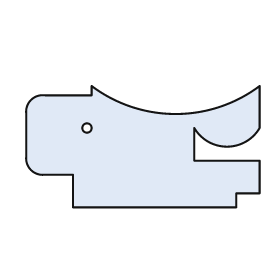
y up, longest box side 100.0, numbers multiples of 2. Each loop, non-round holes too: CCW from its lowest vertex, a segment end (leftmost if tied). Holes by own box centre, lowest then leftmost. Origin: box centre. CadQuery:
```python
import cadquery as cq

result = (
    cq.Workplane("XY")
    .moveTo(-30.0, -26.0)
    .lineTo(40.0, -26.0)
    .lineTo(40.0, -20.0)
    .lineTo(50.0, -20.0)
    .lineTo(50.0, -6.0)
    .lineTo(22.0, -6.0)
    .lineTo(22.0, 8.0)
    .threePointArc((36.0, 0.0), (50.0, 8.0))
    .lineTo(50.0, 26.0)
    .threePointArc((14.0, 14.0), (-22.0, 26.0))
    .lineTo(-22.0, 22.0)
    .lineTo(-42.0, 22.0)
    .threePointArc((-48.0, 20.0), (-50.0, 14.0))
    .lineTo(-50.0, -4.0)
    .threePointArc((-48.0, -10.0), (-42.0, -12.0))
    .lineTo(-30.0, -12.0)
    .close()
    .moveTo(-24.0, 8.0)
    .circle(2.0)
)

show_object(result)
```